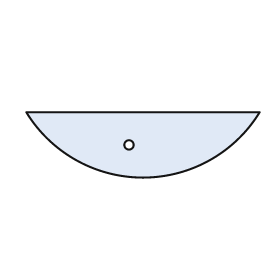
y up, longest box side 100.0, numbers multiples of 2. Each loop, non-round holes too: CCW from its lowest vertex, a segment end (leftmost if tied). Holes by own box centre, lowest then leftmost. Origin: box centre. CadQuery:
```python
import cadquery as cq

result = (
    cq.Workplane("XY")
    .moveTo(-50.0, 14.0)
    .threePointArc((0.0, -14.0), (50.0, 14.0))
    .close()
    .moveTo(-6.0, 0.0)
    .circle(2.0)
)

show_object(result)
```